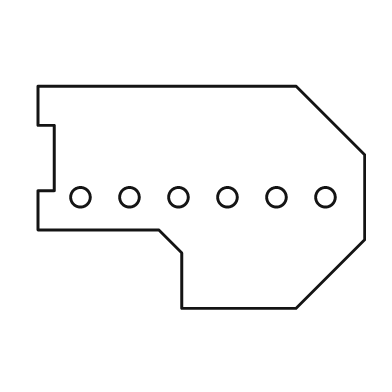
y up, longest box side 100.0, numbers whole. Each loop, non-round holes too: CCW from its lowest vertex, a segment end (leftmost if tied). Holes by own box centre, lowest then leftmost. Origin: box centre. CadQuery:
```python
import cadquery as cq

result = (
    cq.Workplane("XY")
    .moveTo(-6.0, -34.0)
    .lineTo(29.0, -34.0)
    .lineTo(50.0, -13.0)
    .lineTo(50.0, 13.0)
    .lineTo(29.0, 34.0)
    .lineTo(-50.0, 34.0)
    .lineTo(-50.0, 22.0)
    .lineTo(-45.0, 22.0)
    .lineTo(-45.0, 2.0)
    .lineTo(-50.0, 2.0)
    .lineTo(-50.0, -10.0)
    .lineTo(-13.0, -10.0)
    .lineTo(-6.0, -17.0)
    .close()
    .moveTo(-37.0, 0.0)
    .circle(3.0)
    .moveTo(-22.0, 0.0)
    .circle(3.0)
    .moveTo(-7.0, 0.0)
    .circle(3.0)
    .moveTo(8.0, 0.0)
    .circle(3.0)
    .moveTo(23.0, 0.0)
    .circle(3.0)
    .moveTo(38.0, 0.0)
    .circle(3.0)
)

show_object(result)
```